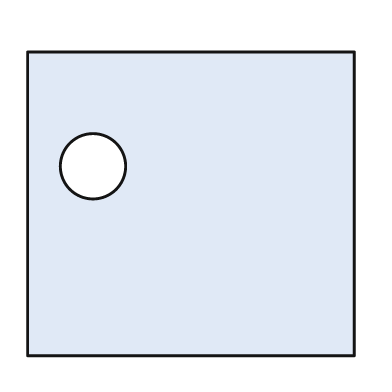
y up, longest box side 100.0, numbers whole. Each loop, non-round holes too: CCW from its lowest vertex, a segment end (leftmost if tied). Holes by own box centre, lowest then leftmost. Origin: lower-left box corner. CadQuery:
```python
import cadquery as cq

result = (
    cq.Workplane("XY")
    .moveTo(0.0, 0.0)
    .lineTo(100.0, 0.0)
    .lineTo(100.0, 93.0)
    .lineTo(0.0, 93.0)
    .close()
    .moveTo(20.0, 58.0)
    .circle(10.0)
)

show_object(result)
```